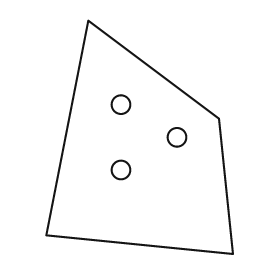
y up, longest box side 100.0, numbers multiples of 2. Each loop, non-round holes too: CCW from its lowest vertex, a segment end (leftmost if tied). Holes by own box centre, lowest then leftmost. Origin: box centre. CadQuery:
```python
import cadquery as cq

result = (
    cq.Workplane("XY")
    .moveTo(40.0, -50.0)
    .lineTo(34.0, 8.0)
    .lineTo(-22.0, 50.0)
    .lineTo(-40.0, -42.0)
    .close()
    .moveTo(-8.0, -14.0)
    .circle(4.0)
    .moveTo(16.0, 0.0)
    .circle(4.0)
    .moveTo(-8.0, 14.0)
    .circle(4.0)
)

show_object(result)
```